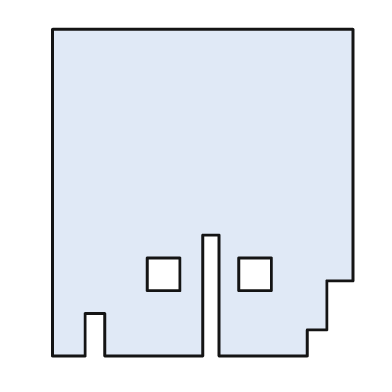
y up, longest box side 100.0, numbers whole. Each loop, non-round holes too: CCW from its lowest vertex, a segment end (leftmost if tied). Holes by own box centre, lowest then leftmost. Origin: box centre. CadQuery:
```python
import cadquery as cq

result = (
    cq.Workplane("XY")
    .moveTo(-46.0, -50.0)
    .lineTo(-36.0, -50.0)
    .lineTo(-36.0, -37.0)
    .lineTo(-30.0, -37.0)
    .lineTo(-30.0, -50.0)
    .lineTo(0.0, -50.0)
    .lineTo(0.0, -13.0)
    .lineTo(5.0, -13.0)
    .lineTo(5.0, -50.0)
    .lineTo(32.0, -50.0)
    .lineTo(32.0, -42.0)
    .lineTo(38.0, -42.0)
    .lineTo(38.0, -27.0)
    .lineTo(46.0, -27.0)
    .lineTo(46.0, 50.0)
    .lineTo(-46.0, 50.0)
    .close()
    .moveTo(-17.0, -30.0)
    .lineTo(-7.0, -30.0)
    .lineTo(-7.0, -20.0)
    .lineTo(-17.0, -20.0)
    .close()
    .moveTo(11.0, -30.0)
    .lineTo(21.0, -30.0)
    .lineTo(21.0, -20.0)
    .lineTo(11.0, -20.0)
    .close()
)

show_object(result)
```